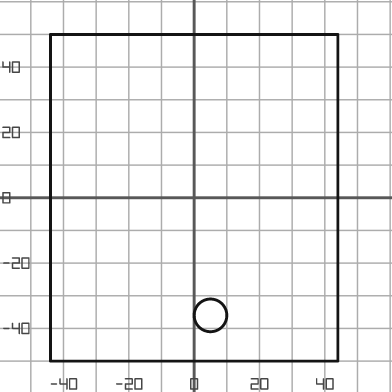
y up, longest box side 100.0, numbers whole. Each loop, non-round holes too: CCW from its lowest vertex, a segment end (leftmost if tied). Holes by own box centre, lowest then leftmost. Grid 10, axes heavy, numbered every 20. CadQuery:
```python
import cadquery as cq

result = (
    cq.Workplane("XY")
    .moveTo(-44.0, -50.0)
    .lineTo(44.0, -50.0)
    .lineTo(44.0, 50.0)
    .lineTo(-44.0, 50.0)
    .close()
    .moveTo(5.0, -36.0)
    .circle(5.0)
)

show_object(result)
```